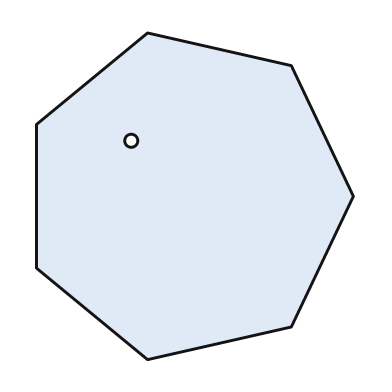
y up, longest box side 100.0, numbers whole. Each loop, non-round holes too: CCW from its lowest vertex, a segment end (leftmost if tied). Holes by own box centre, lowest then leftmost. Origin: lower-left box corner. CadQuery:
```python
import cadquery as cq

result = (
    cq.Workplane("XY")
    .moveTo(34.0, 0.0)
    .lineTo(78.0, 10.0)
    .lineTo(97.0, 50.0)
    .lineTo(78.0, 90.0)
    .lineTo(34.0, 100.0)
    .lineTo(0.0, 72.0)
    .lineTo(0.0, 28.0)
    .close()
    .moveTo(29.0, 67.0)
    .circle(2.0)
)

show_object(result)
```